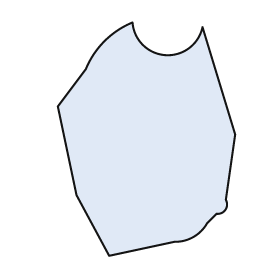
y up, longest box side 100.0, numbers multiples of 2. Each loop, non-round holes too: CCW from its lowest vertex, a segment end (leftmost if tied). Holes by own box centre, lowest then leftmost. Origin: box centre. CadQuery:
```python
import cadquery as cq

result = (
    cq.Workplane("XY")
    .moveTo(-16.0, -50.0)
    .lineTo(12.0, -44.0)
    .threePointArc((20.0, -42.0), (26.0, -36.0))
    .lineTo(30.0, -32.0)
    .threePointArc((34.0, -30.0), (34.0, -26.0))
    .lineTo(38.0, 2.0)
    .lineTo(24.0, 48.0)
    .threePointArc((8.0, 36.0), (-6.0, 50.0))
    .threePointArc((-18.0, 42.0), (-26.0, 30.0))
    .lineTo(-38.0, 14.0)
    .lineTo(-30.0, -24.0)
    .close()
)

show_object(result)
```